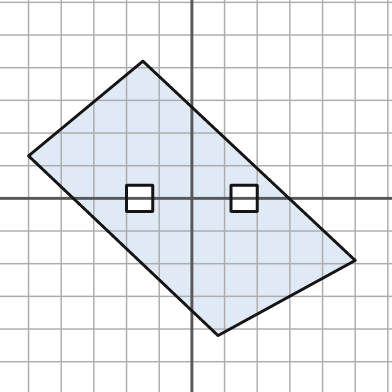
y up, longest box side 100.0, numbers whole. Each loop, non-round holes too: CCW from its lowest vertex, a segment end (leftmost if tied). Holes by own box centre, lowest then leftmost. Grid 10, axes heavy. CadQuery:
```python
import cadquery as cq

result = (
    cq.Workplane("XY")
    .moveTo(8.0, -42.0)
    .lineTo(50.0, -19.0)
    .lineTo(-15.0, 42.0)
    .lineTo(-50.0, 13.0)
    .close()
    .moveTo(-20.0, -4.0)
    .lineTo(-12.0, -4.0)
    .lineTo(-12.0, 4.0)
    .lineTo(-20.0, 4.0)
    .close()
    .moveTo(12.0, -4.0)
    .lineTo(20.0, -4.0)
    .lineTo(20.0, 4.0)
    .lineTo(12.0, 4.0)
    .close()
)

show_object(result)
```